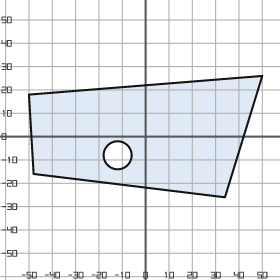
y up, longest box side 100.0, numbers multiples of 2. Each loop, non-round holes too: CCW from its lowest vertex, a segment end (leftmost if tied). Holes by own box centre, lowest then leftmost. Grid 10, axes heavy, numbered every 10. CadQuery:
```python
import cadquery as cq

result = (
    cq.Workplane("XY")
    .moveTo(34.0, -26.0)
    .lineTo(50.0, 26.0)
    .lineTo(-50.0, 18.0)
    .lineTo(-48.0, -16.0)
    .close()
    .moveTo(-12.0, -8.0)
    .circle(6.0)
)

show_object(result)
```